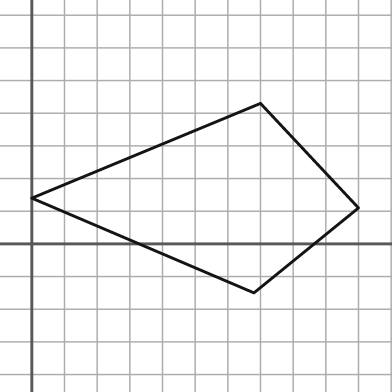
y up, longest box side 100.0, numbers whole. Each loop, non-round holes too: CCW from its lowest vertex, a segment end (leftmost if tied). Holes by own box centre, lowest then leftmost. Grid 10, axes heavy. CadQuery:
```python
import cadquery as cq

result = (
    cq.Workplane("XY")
    .moveTo(68.0, -15.0)
    .lineTo(100.0, 11.0)
    .lineTo(70.0, 43.0)
    .lineTo(0.0, 14.0)
    .close()
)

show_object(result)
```